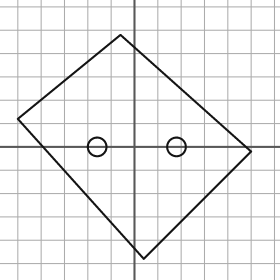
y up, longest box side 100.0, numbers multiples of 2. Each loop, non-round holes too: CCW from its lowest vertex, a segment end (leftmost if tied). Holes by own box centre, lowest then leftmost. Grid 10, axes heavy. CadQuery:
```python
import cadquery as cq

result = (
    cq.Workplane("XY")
    .moveTo(4.0, -48.0)
    .lineTo(50.0, -2.0)
    .lineTo(-6.0, 48.0)
    .lineTo(-50.0, 12.0)
    .close()
    .moveTo(-16.0, 0.0)
    .circle(4.0)
    .moveTo(18.0, 0.0)
    .circle(4.0)
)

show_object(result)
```